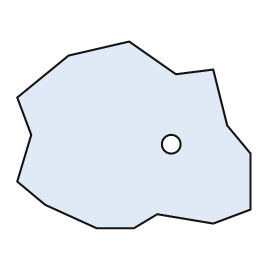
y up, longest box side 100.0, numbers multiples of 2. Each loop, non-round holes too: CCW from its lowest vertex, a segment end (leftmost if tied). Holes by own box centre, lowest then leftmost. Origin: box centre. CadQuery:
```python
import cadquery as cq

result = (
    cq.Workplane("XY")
    .moveTo(-16.0, -40.0)
    .lineTo(0.0, -40.0)
    .lineTo(10.0, -34.0)
    .lineTo(34.0, -38.0)
    .lineTo(50.0, -32.0)
    .lineTo(50.0, -8.0)
    .lineTo(40.0, 4.0)
    .lineTo(34.0, 28.0)
    .lineTo(18.0, 26.0)
    .lineTo(-2.0, 40.0)
    .lineTo(-28.0, 34.0)
    .lineTo(-50.0, 16.0)
    .lineTo(-44.0, 0.0)
    .lineTo(-50.0, -20.0)
    .lineTo(-38.0, -30.0)
    .close()
    .moveTo(16.0, -4.0)
    .circle(4.0)
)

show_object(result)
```